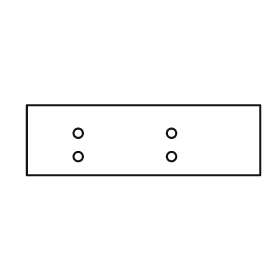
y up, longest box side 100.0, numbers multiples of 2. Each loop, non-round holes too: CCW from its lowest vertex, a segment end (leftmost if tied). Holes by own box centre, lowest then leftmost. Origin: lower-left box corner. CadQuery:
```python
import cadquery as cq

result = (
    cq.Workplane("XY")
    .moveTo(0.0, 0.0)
    .lineTo(100.0, 0.0)
    .lineTo(100.0, 30.0)
    .lineTo(0.0, 30.0)
    .close()
    .moveTo(22.0, 8.0)
    .circle(2.0)
    .moveTo(62.0, 8.0)
    .circle(2.0)
    .moveTo(22.0, 18.0)
    .circle(2.0)
    .moveTo(62.0, 18.0)
    .circle(2.0)
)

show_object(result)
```